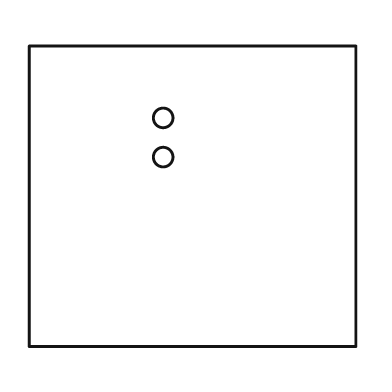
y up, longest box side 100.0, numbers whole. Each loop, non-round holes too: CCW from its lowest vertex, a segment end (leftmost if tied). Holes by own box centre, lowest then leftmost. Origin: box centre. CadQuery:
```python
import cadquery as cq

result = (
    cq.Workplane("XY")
    .moveTo(-50.0, -46.0)
    .lineTo(50.0, -46.0)
    .lineTo(50.0, 46.0)
    .lineTo(-50.0, 46.0)
    .close()
    .moveTo(-9.0, 12.0)
    .circle(3.0)
    .moveTo(-9.0, 24.0)
    .circle(3.0)
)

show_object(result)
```